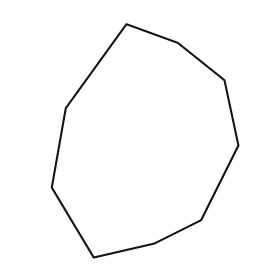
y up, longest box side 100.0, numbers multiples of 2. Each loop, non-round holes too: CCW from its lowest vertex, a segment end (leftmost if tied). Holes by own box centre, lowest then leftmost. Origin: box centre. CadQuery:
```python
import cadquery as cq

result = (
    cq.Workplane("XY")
    .moveTo(-22.0, -50.0)
    .lineTo(4.0, -44.0)
    .lineTo(24.0, -34.0)
    .lineTo(40.0, -2.0)
    .lineTo(34.0, 26.0)
    .lineTo(14.0, 42.0)
    .lineTo(-8.0, 50.0)
    .lineTo(-34.0, 14.0)
    .lineTo(-40.0, -20.0)
    .close()
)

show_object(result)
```